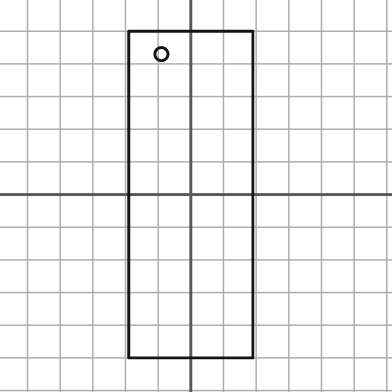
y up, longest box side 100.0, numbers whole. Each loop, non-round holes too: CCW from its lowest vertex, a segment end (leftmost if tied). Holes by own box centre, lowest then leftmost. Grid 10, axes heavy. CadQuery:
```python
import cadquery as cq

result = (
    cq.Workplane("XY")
    .moveTo(-19.0, -50.0)
    .lineTo(19.0, -50.0)
    .lineTo(19.0, 50.0)
    .lineTo(-19.0, 50.0)
    .close()
    .moveTo(-9.0, 43.0)
    .circle(2.0)
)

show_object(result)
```